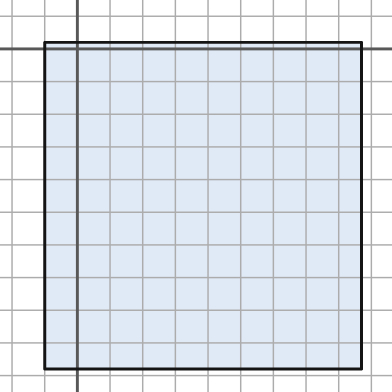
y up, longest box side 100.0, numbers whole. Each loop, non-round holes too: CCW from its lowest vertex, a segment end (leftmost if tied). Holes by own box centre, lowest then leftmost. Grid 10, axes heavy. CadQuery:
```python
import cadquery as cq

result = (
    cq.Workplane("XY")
    .moveTo(-10.0, -98.0)
    .lineTo(87.0, -98.0)
    .lineTo(87.0, 2.0)
    .lineTo(-10.0, 2.0)
    .close()
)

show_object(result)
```